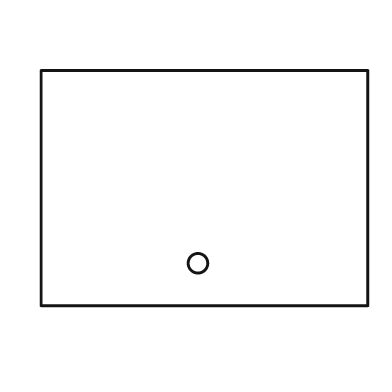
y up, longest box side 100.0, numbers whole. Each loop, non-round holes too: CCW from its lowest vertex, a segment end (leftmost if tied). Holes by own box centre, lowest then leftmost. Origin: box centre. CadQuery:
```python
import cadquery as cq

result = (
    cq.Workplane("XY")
    .moveTo(-50.0, -36.0)
    .lineTo(50.0, -36.0)
    .lineTo(50.0, 36.0)
    .lineTo(-50.0, 36.0)
    .close()
    .moveTo(-2.0, -23.0)
    .circle(3.0)
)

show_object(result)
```